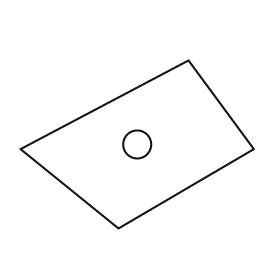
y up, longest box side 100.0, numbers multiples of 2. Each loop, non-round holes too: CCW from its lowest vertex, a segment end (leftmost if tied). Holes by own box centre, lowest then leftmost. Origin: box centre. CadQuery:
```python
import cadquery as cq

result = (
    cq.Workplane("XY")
    .moveTo(-8.0, -36.0)
    .lineTo(50.0, -2.0)
    .lineTo(22.0, 36.0)
    .lineTo(-50.0, -2.0)
    .close()
    .moveTo(0.0, 0.0)
    .circle(6.0)
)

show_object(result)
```